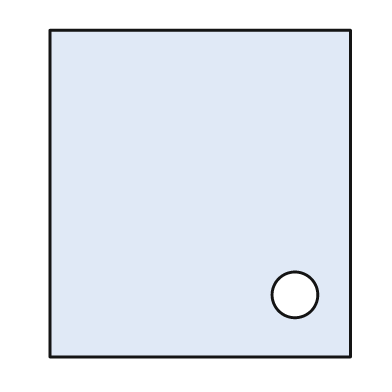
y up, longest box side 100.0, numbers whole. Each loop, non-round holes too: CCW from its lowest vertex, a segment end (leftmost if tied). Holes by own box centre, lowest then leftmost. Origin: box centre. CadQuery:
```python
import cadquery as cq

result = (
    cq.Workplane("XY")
    .moveTo(-46.0, -50.0)
    .lineTo(46.0, -50.0)
    .lineTo(46.0, 50.0)
    .lineTo(-46.0, 50.0)
    .close()
    .moveTo(29.0, -31.0)
    .circle(7.0)
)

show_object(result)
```